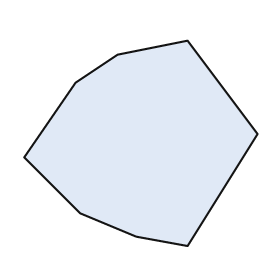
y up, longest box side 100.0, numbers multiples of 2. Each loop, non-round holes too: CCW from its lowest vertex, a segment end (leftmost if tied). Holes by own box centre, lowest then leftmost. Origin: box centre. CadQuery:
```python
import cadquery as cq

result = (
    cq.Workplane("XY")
    .moveTo(20.0, -44.0)
    .lineTo(50.0, 4.0)
    .lineTo(20.0, 44.0)
    .lineTo(-10.0, 38.0)
    .lineTo(-28.0, 26.0)
    .lineTo(-50.0, -6.0)
    .lineTo(-26.0, -30.0)
    .lineTo(-2.0, -40.0)
    .close()
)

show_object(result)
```